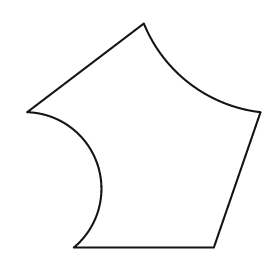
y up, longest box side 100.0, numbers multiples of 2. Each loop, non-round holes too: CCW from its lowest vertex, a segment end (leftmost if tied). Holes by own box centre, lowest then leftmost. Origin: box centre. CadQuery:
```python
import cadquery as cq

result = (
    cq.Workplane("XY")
    .moveTo(-30.0, -48.0)
    .lineTo(30.0, -48.0)
    .lineTo(50.0, 10.0)
    .threePointArc((20.0, 22.0), (0.0, 48.0))
    .lineTo(-50.0, 10.0)
    .threePointArc((-20.0, -12.0), (-30.0, -48.0))
    .close()
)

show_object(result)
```